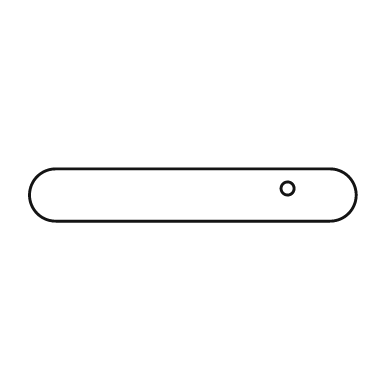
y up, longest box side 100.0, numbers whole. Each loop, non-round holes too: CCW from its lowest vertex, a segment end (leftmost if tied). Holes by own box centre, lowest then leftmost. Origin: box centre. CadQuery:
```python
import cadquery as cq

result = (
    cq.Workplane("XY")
    .moveTo(-42.0, -8.0)
    .lineTo(42.0, -8.0)
    .threePointArc((50.0, 0.0), (42.0, 8.0))
    .lineTo(-42.0, 8.0)
    .threePointArc((-50.0, 0.0), (-42.0, -8.0))
    .close()
    .moveTo(29.0, 2.0)
    .circle(2.0)
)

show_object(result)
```